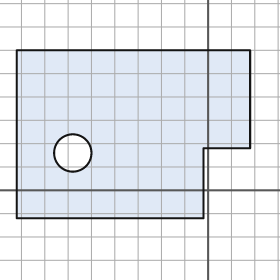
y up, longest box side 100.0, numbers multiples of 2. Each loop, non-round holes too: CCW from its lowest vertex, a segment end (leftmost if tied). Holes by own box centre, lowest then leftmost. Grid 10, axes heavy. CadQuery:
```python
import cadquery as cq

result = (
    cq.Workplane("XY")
    .moveTo(-82.0, -12.0)
    .lineTo(-2.0, -12.0)
    .lineTo(-2.0, 18.0)
    .lineTo(18.0, 18.0)
    .lineTo(18.0, 60.0)
    .lineTo(-82.0, 60.0)
    .close()
    .moveTo(-58.0, 16.0)
    .circle(8.0)
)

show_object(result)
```